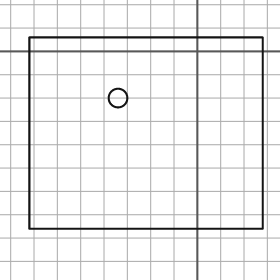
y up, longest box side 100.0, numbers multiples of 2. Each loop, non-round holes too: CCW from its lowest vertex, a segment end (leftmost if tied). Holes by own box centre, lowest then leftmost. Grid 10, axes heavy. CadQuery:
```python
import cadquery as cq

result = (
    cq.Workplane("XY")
    .moveTo(-72.0, -76.0)
    .lineTo(28.0, -76.0)
    .lineTo(28.0, 6.0)
    .lineTo(-72.0, 6.0)
    .close()
    .moveTo(-34.0, -20.0)
    .circle(4.0)
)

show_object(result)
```